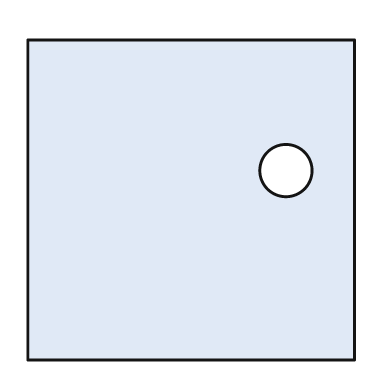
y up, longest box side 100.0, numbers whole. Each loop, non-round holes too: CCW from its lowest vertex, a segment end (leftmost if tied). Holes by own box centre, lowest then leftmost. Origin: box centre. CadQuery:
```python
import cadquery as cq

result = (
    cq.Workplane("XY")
    .moveTo(-50.0, -49.0)
    .lineTo(50.0, -49.0)
    .lineTo(50.0, 49.0)
    .lineTo(-50.0, 49.0)
    .close()
    .moveTo(29.0, 9.0)
    .circle(8.0)
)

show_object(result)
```